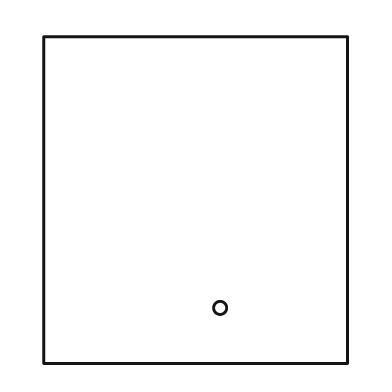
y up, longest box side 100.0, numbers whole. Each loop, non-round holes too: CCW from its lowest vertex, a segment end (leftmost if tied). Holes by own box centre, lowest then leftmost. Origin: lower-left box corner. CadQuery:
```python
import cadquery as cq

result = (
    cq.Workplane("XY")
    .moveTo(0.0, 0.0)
    .lineTo(93.0, 0.0)
    .lineTo(93.0, 100.0)
    .lineTo(0.0, 100.0)
    .close()
    .moveTo(54.0, 17.0)
    .circle(2.0)
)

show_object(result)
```